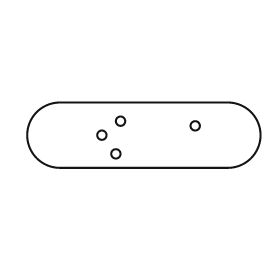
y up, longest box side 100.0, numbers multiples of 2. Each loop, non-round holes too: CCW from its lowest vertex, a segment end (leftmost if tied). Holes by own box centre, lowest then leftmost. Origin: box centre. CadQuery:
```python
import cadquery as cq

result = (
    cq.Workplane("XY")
    .moveTo(-36.0, -14.0)
    .lineTo(36.0, -14.0)
    .threePointArc((50.0, 0.0), (36.0, 14.0))
    .lineTo(-36.0, 14.0)
    .threePointArc((-50.0, 0.0), (-36.0, -14.0))
    .close()
    .moveTo(-12.0, -8.0)
    .circle(2.0)
    .moveTo(-18.0, 0.0)
    .circle(2.0)
    .moveTo(22.0, 4.0)
    .circle(2.0)
    .moveTo(-10.0, 6.0)
    .circle(2.0)
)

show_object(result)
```